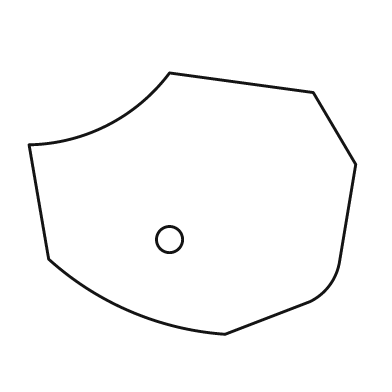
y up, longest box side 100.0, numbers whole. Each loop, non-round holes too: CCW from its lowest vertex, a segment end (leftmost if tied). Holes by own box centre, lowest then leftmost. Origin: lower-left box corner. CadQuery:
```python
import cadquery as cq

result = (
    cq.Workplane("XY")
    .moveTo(60.0, 0.0)
    .lineTo(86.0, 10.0)
    .threePointArc((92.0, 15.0), (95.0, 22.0))
    .lineTo(100.0, 52.0)
    .lineTo(87.0, 74.0)
    .lineTo(43.0, 80.0)
    .threePointArc((24.0, 64.0), (0.0, 58.0))
    .lineTo(6.0, 23.0)
    .threePointArc((31.0, 7.0), (60.0, 0.0))
    .close()
    .moveTo(43.0, 29.0)
    .circle(4.0)
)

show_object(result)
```